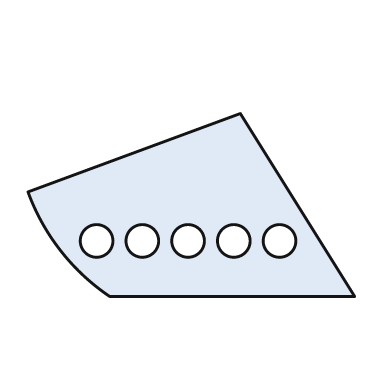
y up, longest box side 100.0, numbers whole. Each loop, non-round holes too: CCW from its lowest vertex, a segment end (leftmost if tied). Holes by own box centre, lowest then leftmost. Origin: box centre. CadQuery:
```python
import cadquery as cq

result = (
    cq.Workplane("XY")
    .moveTo(-25.0, -28.0)
    .lineTo(50.0, -28.0)
    .lineTo(15.0, 28.0)
    .lineTo(-50.0, 4.0)
    .threePointArc((-40.0, -14.0), (-25.0, -28.0))
    .close()
    .moveTo(-29.0, -11.0)
    .circle(5.0)
    .moveTo(-15.0, -11.0)
    .circle(5.0)
    .moveTo(-1.0, -11.0)
    .circle(5.0)
    .moveTo(13.0, -11.0)
    .circle(5.0)
    .moveTo(27.0, -11.0)
    .circle(5.0)
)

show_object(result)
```